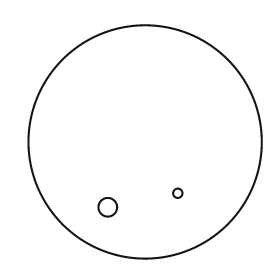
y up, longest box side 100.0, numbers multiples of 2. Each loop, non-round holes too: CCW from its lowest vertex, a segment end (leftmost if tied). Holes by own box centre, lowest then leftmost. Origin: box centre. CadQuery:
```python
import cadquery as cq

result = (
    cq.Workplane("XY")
    .moveTo(0.0, 0.0)
    .circle(50.0)
    .moveTo(-16.0, -28.0)
    .circle(4.0)
    .moveTo(14.0, -22.0)
    .circle(2.0)
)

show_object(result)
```